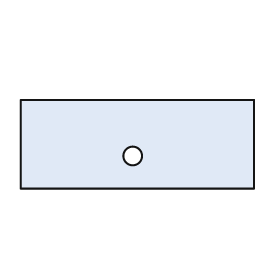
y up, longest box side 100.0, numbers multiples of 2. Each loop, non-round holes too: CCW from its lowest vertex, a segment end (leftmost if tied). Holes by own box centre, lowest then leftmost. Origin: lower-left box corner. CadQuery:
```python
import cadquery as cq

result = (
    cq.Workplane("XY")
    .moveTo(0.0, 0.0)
    .lineTo(100.0, 0.0)
    .lineTo(100.0, 38.0)
    .lineTo(0.0, 38.0)
    .close()
    .moveTo(48.0, 14.0)
    .circle(4.0)
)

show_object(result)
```